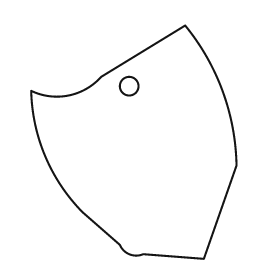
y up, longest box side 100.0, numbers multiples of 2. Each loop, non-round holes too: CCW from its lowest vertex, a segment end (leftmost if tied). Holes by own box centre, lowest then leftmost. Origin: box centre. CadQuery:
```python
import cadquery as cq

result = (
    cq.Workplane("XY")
    .moveTo(30.0, -50.0)
    .lineTo(44.0, -10.0)
    .threePointArc((38.0, 22.0), (22.0, 50.0))
    .lineTo(-14.0, 28.0)
    .threePointArc((-28.0, 20.0), (-44.0, 22.0))
    .threePointArc((-38.0, -6.0), (-22.0, -30.0))
    .lineTo(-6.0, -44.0)
    .threePointArc((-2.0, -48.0), (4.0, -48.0))
    .close()
    .moveTo(-2.0, 24.0)
    .circle(4.0)
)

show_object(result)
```